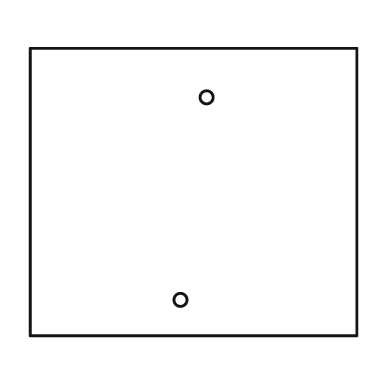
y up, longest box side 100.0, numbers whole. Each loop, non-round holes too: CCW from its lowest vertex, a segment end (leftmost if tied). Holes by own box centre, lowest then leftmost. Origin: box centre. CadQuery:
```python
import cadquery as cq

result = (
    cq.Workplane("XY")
    .moveTo(-50.0, -44.0)
    .lineTo(50.0, -44.0)
    .lineTo(50.0, 44.0)
    .lineTo(-50.0, 44.0)
    .close()
    .moveTo(-4.0, -33.0)
    .circle(2.0)
    .moveTo(4.0, 29.0)
    .circle(2.0)
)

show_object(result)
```